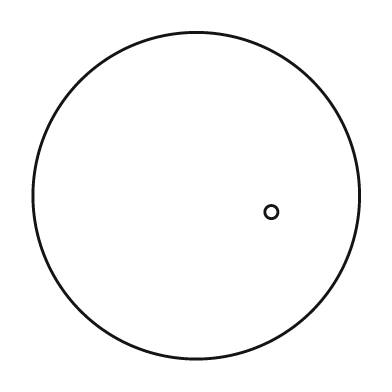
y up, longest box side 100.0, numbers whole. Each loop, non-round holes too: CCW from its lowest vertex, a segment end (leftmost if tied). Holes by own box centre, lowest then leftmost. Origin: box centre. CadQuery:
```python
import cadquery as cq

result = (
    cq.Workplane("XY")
    .moveTo(0.0, 0.0)
    .circle(50.0)
    .moveTo(23.0, -5.0)
    .circle(2.0)
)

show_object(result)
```